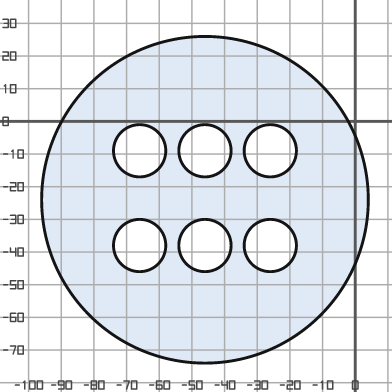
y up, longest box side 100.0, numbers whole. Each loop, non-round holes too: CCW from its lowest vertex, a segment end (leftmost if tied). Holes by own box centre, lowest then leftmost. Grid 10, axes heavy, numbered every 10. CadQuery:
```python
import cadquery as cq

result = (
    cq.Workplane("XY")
    .moveTo(-46.0, -24.0)
    .circle(50.0)
    .moveTo(-66.0, -38.0)
    .circle(8.0)
    .moveTo(-46.0, -38.0)
    .circle(8.0)
    .moveTo(-26.0, -38.0)
    .circle(8.0)
    .moveTo(-66.0, -9.0)
    .circle(8.0)
    .moveTo(-46.0, -9.0)
    .circle(8.0)
    .moveTo(-26.0, -9.0)
    .circle(8.0)
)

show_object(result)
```